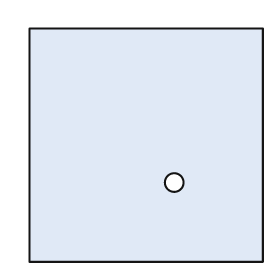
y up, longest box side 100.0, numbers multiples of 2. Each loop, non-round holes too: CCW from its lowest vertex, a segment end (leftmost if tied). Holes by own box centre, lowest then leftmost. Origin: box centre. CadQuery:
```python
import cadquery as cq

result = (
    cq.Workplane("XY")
    .moveTo(-50.0, -50.0)
    .lineTo(50.0, -50.0)
    .lineTo(50.0, 50.0)
    .lineTo(-50.0, 50.0)
    .close()
    .moveTo(12.0, -16.0)
    .circle(4.0)
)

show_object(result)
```